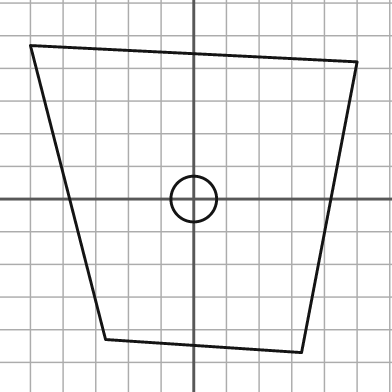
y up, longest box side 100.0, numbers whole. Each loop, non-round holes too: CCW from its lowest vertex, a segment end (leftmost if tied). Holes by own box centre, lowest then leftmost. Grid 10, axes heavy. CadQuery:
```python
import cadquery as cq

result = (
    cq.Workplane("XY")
    .moveTo(33.0, -47.0)
    .lineTo(50.0, 42.0)
    .lineTo(-50.0, 47.0)
    .lineTo(-27.0, -43.0)
    .close()
    .moveTo(0.0, 0.0)
    .circle(7.0)
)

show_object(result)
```